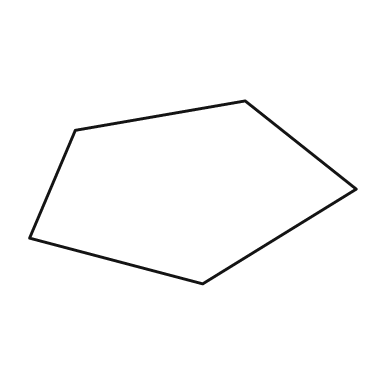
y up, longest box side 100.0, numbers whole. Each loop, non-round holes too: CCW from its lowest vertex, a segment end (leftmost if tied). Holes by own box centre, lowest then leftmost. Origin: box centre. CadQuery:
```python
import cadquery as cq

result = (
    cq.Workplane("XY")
    .moveTo(3.0, -28.0)
    .lineTo(50.0, 1.0)
    .lineTo(16.0, 28.0)
    .lineTo(-36.0, 19.0)
    .lineTo(-50.0, -14.0)
    .close()
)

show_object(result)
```